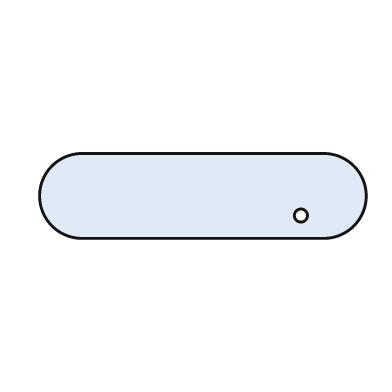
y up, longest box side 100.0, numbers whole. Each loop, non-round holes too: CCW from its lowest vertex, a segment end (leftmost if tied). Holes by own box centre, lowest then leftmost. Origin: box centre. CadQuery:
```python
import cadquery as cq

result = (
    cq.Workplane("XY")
    .moveTo(-37.0, -13.0)
    .lineTo(37.0, -13.0)
    .threePointArc((50.0, 0.0), (37.0, 13.0))
    .lineTo(-37.0, 13.0)
    .threePointArc((-50.0, 0.0), (-37.0, -13.0))
    .close()
    .moveTo(30.0, -6.0)
    .circle(2.0)
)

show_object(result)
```